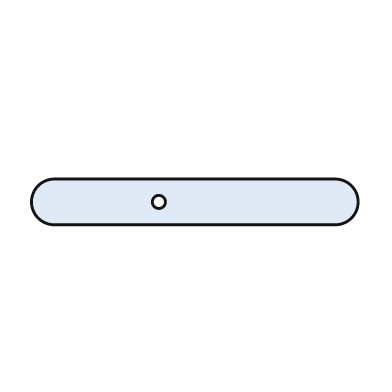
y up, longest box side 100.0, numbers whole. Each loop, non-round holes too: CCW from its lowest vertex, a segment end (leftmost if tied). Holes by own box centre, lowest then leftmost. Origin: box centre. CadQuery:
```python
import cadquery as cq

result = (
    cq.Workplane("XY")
    .moveTo(-43.0, -7.0)
    .lineTo(43.0, -7.0)
    .threePointArc((50.0, 0.0), (43.0, 7.0))
    .lineTo(-43.0, 7.0)
    .threePointArc((-50.0, 0.0), (-43.0, -7.0))
    .close()
    .moveTo(-11.0, 0.0)
    .circle(2.0)
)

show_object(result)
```